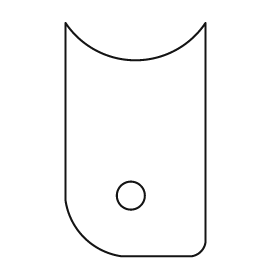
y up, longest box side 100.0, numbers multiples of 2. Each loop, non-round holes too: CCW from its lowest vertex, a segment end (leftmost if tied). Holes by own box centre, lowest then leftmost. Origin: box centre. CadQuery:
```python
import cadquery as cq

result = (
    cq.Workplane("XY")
    .moveTo(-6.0, -50.0)
    .lineTo(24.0, -50.0)
    .threePointArc((28.0, -48.0), (30.0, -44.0))
    .lineTo(30.0, 50.0)
    .threePointArc((0.0, 34.0), (-30.0, 50.0))
    .lineTo(-30.0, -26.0)
    .threePointArc((-22.0, -42.0), (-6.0, -50.0))
    .close()
    .moveTo(-2.0, -24.0)
    .circle(6.0)
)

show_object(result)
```